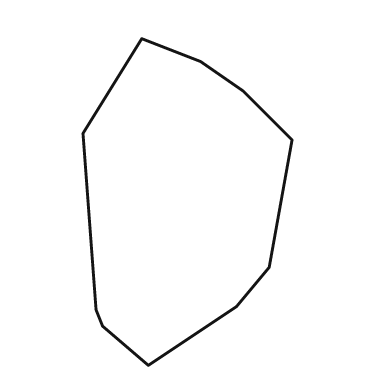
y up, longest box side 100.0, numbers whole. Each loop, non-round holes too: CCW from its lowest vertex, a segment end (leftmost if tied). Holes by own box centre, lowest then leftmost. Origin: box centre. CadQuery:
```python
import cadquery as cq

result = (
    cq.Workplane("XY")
    .moveTo(-12.0, -50.0)
    .lineTo(15.0, -32.0)
    .lineTo(25.0, -20.0)
    .lineTo(32.0, 19.0)
    .lineTo(17.0, 34.0)
    .lineTo(4.0, 43.0)
    .lineTo(-14.0, 50.0)
    .lineTo(-32.0, 21.0)
    .lineTo(-28.0, -33.0)
    .lineTo(-26.0, -38.0)
    .close()
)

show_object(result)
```